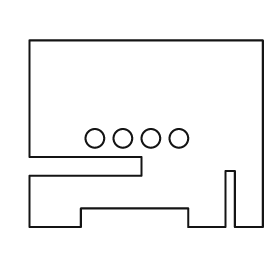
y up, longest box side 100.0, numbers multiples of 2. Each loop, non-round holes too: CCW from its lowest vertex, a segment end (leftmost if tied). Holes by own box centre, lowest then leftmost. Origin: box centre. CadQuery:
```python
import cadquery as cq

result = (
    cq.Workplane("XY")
    .moveTo(-50.0, -40.0)
    .lineTo(-28.0, -40.0)
    .lineTo(-28.0, -32.0)
    .lineTo(18.0, -32.0)
    .lineTo(18.0, -40.0)
    .lineTo(34.0, -40.0)
    .lineTo(34.0, -16.0)
    .lineTo(38.0, -16.0)
    .lineTo(38.0, -40.0)
    .lineTo(50.0, -40.0)
    .lineTo(50.0, 40.0)
    .lineTo(-50.0, 40.0)
    .lineTo(-50.0, -10.0)
    .lineTo(-2.0, -10.0)
    .lineTo(-2.0, -18.0)
    .lineTo(-50.0, -18.0)
    .close()
    .moveTo(-22.0, -2.0)
    .circle(4.0)
    .moveTo(-10.0, -2.0)
    .circle(4.0)
    .moveTo(2.0, -2.0)
    .circle(4.0)
    .moveTo(14.0, -2.0)
    .circle(4.0)
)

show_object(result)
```